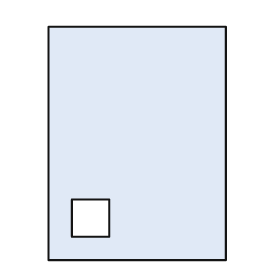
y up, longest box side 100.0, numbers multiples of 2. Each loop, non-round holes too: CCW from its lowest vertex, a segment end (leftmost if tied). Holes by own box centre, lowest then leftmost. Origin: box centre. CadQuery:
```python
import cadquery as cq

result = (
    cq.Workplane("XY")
    .moveTo(-38.0, -50.0)
    .lineTo(38.0, -50.0)
    .lineTo(38.0, 50.0)
    .lineTo(-38.0, 50.0)
    .close()
    .moveTo(-28.0, -40.0)
    .lineTo(-12.0, -40.0)
    .lineTo(-12.0, -24.0)
    .lineTo(-28.0, -24.0)
    .close()
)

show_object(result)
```